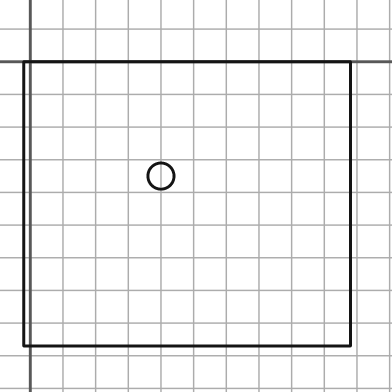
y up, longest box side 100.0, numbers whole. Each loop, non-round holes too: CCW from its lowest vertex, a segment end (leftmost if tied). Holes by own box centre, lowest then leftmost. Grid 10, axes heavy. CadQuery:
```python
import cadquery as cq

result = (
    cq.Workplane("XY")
    .moveTo(-2.0, -87.0)
    .lineTo(98.0, -87.0)
    .lineTo(98.0, 0.0)
    .lineTo(-2.0, 0.0)
    .close()
    .moveTo(40.0, -35.0)
    .circle(4.0)
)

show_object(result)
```